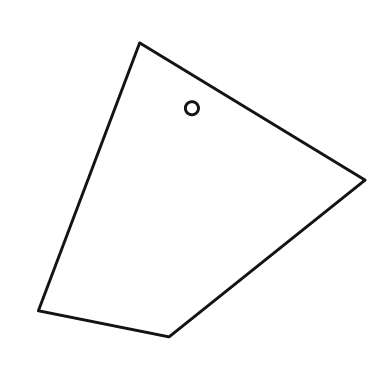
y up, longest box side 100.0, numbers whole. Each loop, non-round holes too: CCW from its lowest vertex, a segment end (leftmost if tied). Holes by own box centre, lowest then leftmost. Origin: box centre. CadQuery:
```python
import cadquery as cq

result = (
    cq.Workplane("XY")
    .moveTo(-10.0, -45.0)
    .lineTo(50.0, 3.0)
    .lineTo(-19.0, 45.0)
    .lineTo(-50.0, -37.0)
    .close()
    .moveTo(-3.0, 25.0)
    .circle(2.0)
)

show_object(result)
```